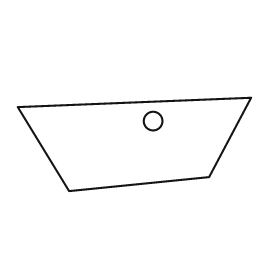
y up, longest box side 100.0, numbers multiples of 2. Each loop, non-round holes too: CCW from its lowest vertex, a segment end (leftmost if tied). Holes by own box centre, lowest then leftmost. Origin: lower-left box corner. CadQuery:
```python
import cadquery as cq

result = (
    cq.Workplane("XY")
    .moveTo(22.0, 0.0)
    .lineTo(82.0, 6.0)
    .lineTo(100.0, 40.0)
    .lineTo(0.0, 36.0)
    .close()
    .moveTo(58.0, 30.0)
    .circle(4.0)
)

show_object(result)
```